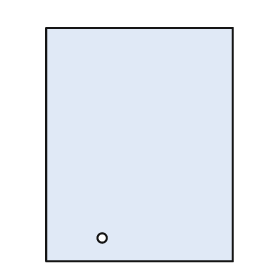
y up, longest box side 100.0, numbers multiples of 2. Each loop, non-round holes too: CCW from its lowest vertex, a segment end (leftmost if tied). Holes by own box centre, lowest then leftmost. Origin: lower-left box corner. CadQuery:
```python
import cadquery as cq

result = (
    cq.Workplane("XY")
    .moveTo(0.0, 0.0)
    .lineTo(80.0, 0.0)
    .lineTo(80.0, 100.0)
    .lineTo(0.0, 100.0)
    .close()
    .moveTo(24.0, 10.0)
    .circle(2.0)
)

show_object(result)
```